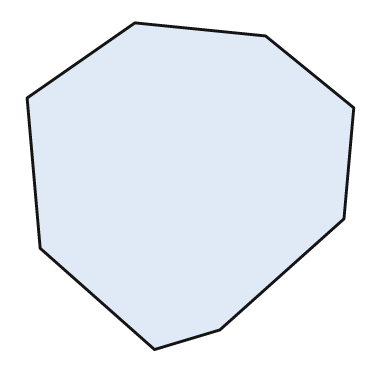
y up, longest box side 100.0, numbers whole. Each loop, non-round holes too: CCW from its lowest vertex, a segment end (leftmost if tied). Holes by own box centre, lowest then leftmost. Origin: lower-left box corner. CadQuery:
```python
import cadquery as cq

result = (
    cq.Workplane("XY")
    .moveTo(39.0, 0.0)
    .lineTo(59.0, 6.0)
    .lineTo(97.0, 40.0)
    .lineTo(100.0, 74.0)
    .lineTo(73.0, 96.0)
    .lineTo(33.0, 100.0)
    .lineTo(0.0, 77.0)
    .lineTo(4.0, 31.0)
    .close()
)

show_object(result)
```